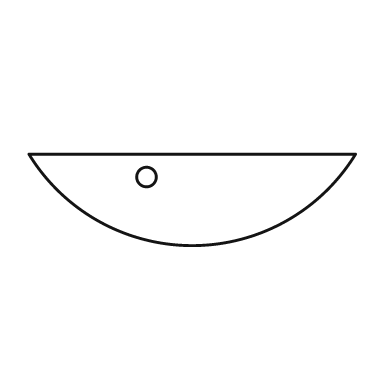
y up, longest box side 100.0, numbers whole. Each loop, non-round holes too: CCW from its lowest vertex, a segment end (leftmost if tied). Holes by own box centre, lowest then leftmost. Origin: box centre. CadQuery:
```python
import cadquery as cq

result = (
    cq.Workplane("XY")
    .moveTo(-50.0, 14.0)
    .threePointArc((0.0, -14.0), (50.0, 14.0))
    .close()
    .moveTo(-14.0, 7.0)
    .circle(3.0)
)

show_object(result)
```